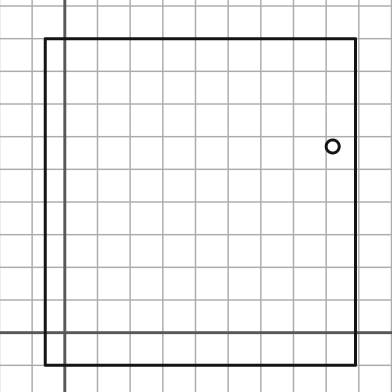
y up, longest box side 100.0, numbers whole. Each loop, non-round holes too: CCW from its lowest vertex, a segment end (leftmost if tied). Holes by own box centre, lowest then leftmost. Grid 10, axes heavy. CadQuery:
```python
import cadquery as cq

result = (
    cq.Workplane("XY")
    .moveTo(-6.0, -10.0)
    .lineTo(89.0, -10.0)
    .lineTo(89.0, 90.0)
    .lineTo(-6.0, 90.0)
    .close()
    .moveTo(82.0, 57.0)
    .circle(2.0)
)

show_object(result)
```